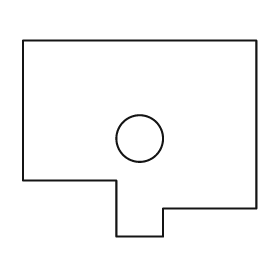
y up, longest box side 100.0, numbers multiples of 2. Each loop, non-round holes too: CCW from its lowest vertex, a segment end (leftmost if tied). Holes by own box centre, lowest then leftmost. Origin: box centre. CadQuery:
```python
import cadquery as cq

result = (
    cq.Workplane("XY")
    .moveTo(-10.0, -42.0)
    .lineTo(10.0, -42.0)
    .lineTo(10.0, -30.0)
    .lineTo(50.0, -30.0)
    .lineTo(50.0, 42.0)
    .lineTo(-50.0, 42.0)
    .lineTo(-50.0, -18.0)
    .lineTo(-10.0, -18.0)
    .close()
    .moveTo(0.0, 0.0)
    .circle(10.0)
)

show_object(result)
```